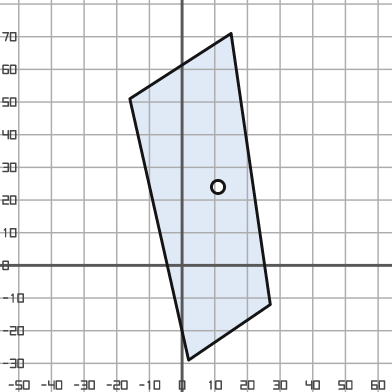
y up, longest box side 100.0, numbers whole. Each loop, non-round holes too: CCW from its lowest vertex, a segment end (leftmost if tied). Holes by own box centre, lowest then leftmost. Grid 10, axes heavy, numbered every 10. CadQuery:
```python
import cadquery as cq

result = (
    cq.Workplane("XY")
    .moveTo(2.0, -29.0)
    .lineTo(27.0, -12.0)
    .lineTo(15.0, 71.0)
    .lineTo(-16.0, 51.0)
    .close()
    .moveTo(11.0, 24.0)
    .circle(2.0)
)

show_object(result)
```